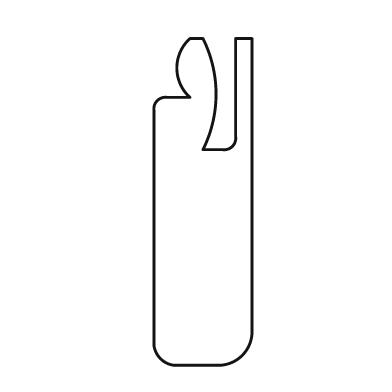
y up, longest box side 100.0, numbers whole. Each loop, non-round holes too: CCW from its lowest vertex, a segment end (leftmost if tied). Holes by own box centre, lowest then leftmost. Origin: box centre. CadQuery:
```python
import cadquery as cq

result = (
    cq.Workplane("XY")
    .moveTo(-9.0, -50.0)
    .lineTo(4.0, -50.0)
    .threePointArc((12.0, -47.0), (15.0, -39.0))
    .lineTo(15.0, 50.0)
    .lineTo(10.0, 50.0)
    .lineTo(10.0, 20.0)
    .threePointArc((9.0, 17.0), (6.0, 16.0))
    .lineTo(0.0, 16.0)
    .threePointArc((4.0, 33.0), (0.0, 50.0))
    .lineTo(-4.0, 50.0)
    .threePointArc((-8.0, 41.0), (-4.0, 32.0))
    .lineTo(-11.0, 32.0)
    .threePointArc((-14.0, 31.0), (-15.0, 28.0))
    .lineTo(-15.0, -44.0)
    .threePointArc((-13.0, -48.0), (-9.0, -50.0))
    .close()
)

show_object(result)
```